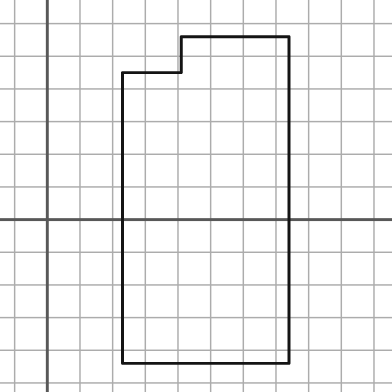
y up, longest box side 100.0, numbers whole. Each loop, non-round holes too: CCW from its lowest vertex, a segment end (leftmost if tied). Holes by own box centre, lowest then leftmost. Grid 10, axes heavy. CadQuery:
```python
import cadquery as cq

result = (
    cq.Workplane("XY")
    .moveTo(23.0, -44.0)
    .lineTo(74.0, -44.0)
    .lineTo(74.0, 56.0)
    .lineTo(41.0, 56.0)
    .lineTo(41.0, 45.0)
    .lineTo(23.0, 45.0)
    .close()
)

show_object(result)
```